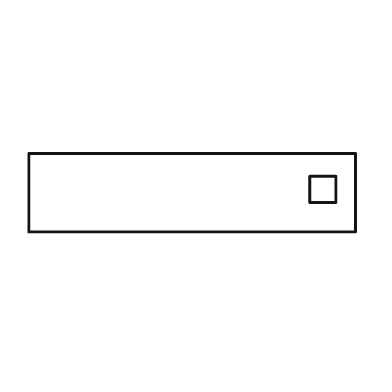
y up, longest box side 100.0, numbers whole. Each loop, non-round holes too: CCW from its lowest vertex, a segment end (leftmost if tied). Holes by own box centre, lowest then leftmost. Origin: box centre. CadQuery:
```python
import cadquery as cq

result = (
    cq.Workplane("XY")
    .moveTo(-50.0, -12.0)
    .lineTo(50.0, -12.0)
    .lineTo(50.0, 12.0)
    .lineTo(-50.0, 12.0)
    .close()
    .moveTo(36.0, -3.0)
    .lineTo(44.0, -3.0)
    .lineTo(44.0, 5.0)
    .lineTo(36.0, 5.0)
    .close()
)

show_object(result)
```